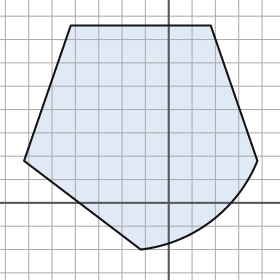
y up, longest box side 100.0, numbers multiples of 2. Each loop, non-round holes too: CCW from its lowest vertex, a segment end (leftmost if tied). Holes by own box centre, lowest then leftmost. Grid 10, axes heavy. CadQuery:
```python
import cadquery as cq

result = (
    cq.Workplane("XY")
    .moveTo(-12.0, -20.0)
    .threePointArc((18.0, -8.0), (38.0, 18.0))
    .lineTo(18.0, 76.0)
    .lineTo(-42.0, 76.0)
    .lineTo(-62.0, 18.0)
    .close()
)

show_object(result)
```